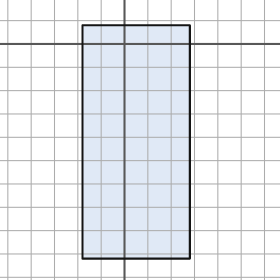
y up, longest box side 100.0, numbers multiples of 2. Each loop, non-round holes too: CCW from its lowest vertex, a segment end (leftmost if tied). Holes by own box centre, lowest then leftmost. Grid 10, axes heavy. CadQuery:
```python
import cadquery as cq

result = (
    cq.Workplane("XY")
    .moveTo(-18.0, -92.0)
    .lineTo(28.0, -92.0)
    .lineTo(28.0, 8.0)
    .lineTo(-18.0, 8.0)
    .close()
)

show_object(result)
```